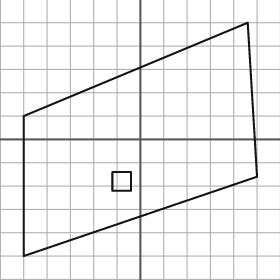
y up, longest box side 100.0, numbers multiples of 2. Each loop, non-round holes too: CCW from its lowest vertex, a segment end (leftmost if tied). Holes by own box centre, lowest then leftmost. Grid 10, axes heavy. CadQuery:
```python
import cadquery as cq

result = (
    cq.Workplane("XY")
    .moveTo(-50.0, -50.0)
    .lineTo(50.0, -16.0)
    .lineTo(46.0, 50.0)
    .lineTo(-50.0, 10.0)
    .close()
    .moveTo(-12.0, -22.0)
    .lineTo(-4.0, -22.0)
    .lineTo(-4.0, -14.0)
    .lineTo(-12.0, -14.0)
    .close()
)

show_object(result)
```